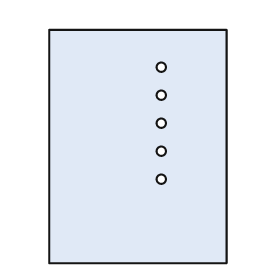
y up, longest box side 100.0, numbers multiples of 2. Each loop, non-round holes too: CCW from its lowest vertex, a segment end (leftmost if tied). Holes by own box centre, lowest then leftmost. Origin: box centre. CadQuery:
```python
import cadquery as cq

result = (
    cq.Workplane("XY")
    .moveTo(-38.0, -50.0)
    .lineTo(38.0, -50.0)
    .lineTo(38.0, 50.0)
    .lineTo(-38.0, 50.0)
    .close()
    .moveTo(10.0, -14.0)
    .circle(2.0)
    .moveTo(10.0, -2.0)
    .circle(2.0)
    .moveTo(10.0, 10.0)
    .circle(2.0)
    .moveTo(10.0, 22.0)
    .circle(2.0)
    .moveTo(10.0, 34.0)
    .circle(2.0)
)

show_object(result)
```